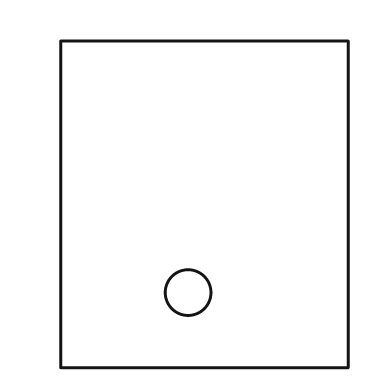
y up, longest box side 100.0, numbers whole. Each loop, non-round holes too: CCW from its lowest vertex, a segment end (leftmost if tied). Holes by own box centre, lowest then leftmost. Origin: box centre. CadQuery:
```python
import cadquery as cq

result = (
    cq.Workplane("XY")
    .moveTo(-44.0, -50.0)
    .lineTo(44.0, -50.0)
    .lineTo(44.0, 50.0)
    .lineTo(-44.0, 50.0)
    .close()
    .moveTo(-5.0, -27.0)
    .circle(7.0)
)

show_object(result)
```